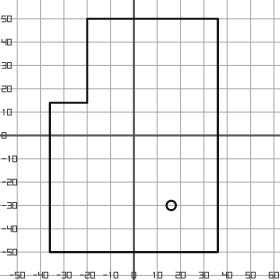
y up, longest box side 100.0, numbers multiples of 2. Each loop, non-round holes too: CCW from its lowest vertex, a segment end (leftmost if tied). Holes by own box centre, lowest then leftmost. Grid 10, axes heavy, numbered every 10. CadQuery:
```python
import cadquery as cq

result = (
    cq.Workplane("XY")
    .moveTo(-36.0, -50.0)
    .lineTo(36.0, -50.0)
    .lineTo(36.0, 50.0)
    .lineTo(-20.0, 50.0)
    .lineTo(-20.0, 14.0)
    .lineTo(-36.0, 14.0)
    .close()
    .moveTo(16.0, -30.0)
    .circle(2.0)
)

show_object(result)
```